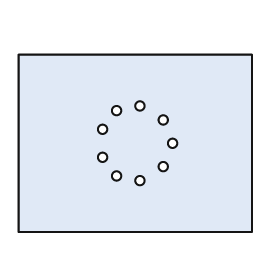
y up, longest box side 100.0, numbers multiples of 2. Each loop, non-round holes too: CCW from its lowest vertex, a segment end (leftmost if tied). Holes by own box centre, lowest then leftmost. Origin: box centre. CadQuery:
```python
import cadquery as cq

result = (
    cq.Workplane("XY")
    .moveTo(-50.0, -38.0)
    .lineTo(50.0, -38.0)
    .lineTo(50.0, 38.0)
    .lineTo(-50.0, 38.0)
    .close()
    .moveTo(2.0, -16.0)
    .circle(2.0)
    .moveTo(-8.0, -14.0)
    .circle(2.0)
    .moveTo(12.0, -10.0)
    .circle(2.0)
    .moveTo(-14.0, -6.0)
    .circle(2.0)
    .moveTo(16.0, 0.0)
    .circle(2.0)
    .moveTo(-14.0, 6.0)
    .circle(2.0)
    .moveTo(12.0, 10.0)
    .circle(2.0)
    .moveTo(-8.0, 14.0)
    .circle(2.0)
    .moveTo(2.0, 16.0)
    .circle(2.0)
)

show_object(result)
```